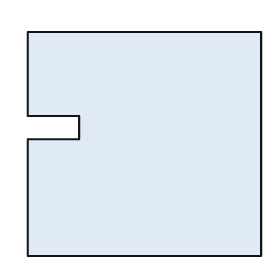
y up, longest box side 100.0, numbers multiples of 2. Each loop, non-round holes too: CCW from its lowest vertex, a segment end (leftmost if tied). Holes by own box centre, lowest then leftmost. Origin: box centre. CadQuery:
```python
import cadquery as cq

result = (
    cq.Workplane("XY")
    .moveTo(-50.0, -48.0)
    .lineTo(50.0, -48.0)
    .lineTo(50.0, 48.0)
    .lineTo(-50.0, 48.0)
    .lineTo(-50.0, 12.0)
    .lineTo(-28.0, 12.0)
    .lineTo(-28.0, 2.0)
    .lineTo(-50.0, 2.0)
    .close()
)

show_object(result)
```